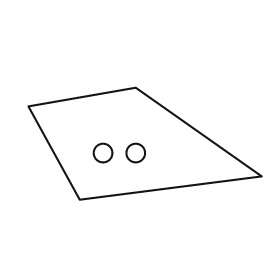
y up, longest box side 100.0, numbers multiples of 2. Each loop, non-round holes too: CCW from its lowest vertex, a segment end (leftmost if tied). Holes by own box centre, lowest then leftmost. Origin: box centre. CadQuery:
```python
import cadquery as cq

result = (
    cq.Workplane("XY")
    .moveTo(-28.0, -24.0)
    .lineTo(50.0, -14.0)
    .lineTo(-4.0, 24.0)
    .lineTo(-50.0, 16.0)
    .close()
    .moveTo(-18.0, -4.0)
    .circle(4.0)
    .moveTo(-4.0, -4.0)
    .circle(4.0)
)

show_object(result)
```